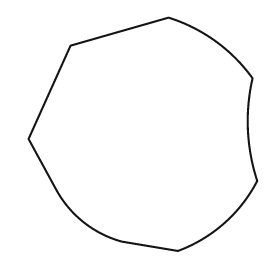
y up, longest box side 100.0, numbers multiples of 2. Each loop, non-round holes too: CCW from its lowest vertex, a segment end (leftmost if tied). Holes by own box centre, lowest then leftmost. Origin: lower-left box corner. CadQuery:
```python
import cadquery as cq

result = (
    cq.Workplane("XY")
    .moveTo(64.0, 0.0)
    .threePointArc((84.0, 12.0), (98.0, 30.0))
    .threePointArc((94.0, 52.0), (96.0, 74.0))
    .threePointArc((80.0, 90.0), (60.0, 100.0))
    .lineTo(18.0, 88.0)
    .lineTo(0.0, 48.0)
    .lineTo(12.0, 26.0)
    .threePointArc((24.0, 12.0), (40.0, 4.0))
    .close()
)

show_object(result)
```